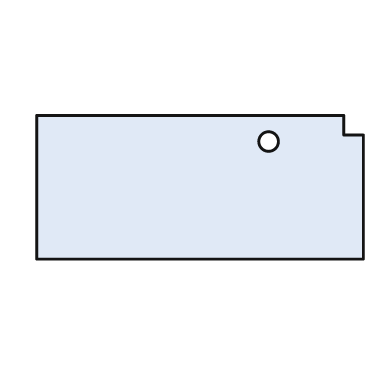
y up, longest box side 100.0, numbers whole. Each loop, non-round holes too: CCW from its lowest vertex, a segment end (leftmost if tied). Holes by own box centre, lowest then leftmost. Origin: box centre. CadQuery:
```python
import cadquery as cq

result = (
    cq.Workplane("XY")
    .moveTo(-50.0, -22.0)
    .lineTo(50.0, -22.0)
    .lineTo(50.0, 16.0)
    .lineTo(44.0, 16.0)
    .lineTo(44.0, 22.0)
    .lineTo(-50.0, 22.0)
    .close()
    .moveTo(21.0, 14.0)
    .circle(3.0)
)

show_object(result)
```